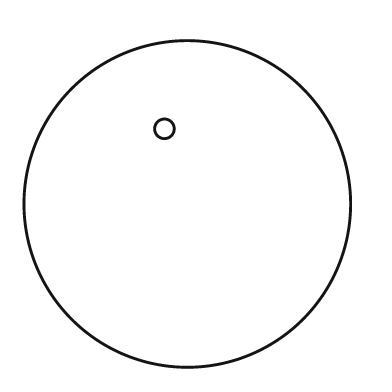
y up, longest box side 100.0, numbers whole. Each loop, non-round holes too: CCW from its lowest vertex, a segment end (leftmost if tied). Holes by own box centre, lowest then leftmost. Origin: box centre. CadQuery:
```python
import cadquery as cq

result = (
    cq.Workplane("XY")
    .moveTo(0.0, 0.0)
    .circle(50.0)
    .moveTo(-7.0, 23.0)
    .circle(3.0)
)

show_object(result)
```